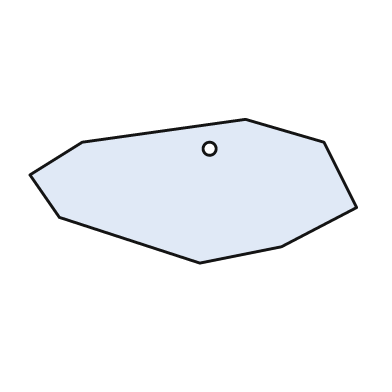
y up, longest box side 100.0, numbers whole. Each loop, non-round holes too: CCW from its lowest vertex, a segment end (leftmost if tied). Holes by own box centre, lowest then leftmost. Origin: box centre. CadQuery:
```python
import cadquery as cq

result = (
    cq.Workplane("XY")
    .moveTo(2.0, -22.0)
    .lineTo(27.0, -17.0)
    .lineTo(50.0, -5.0)
    .lineTo(40.0, 15.0)
    .lineTo(16.0, 22.0)
    .lineTo(-34.0, 15.0)
    .lineTo(-50.0, 5.0)
    .lineTo(-41.0, -8.0)
    .close()
    .moveTo(5.0, 13.0)
    .circle(2.0)
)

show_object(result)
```